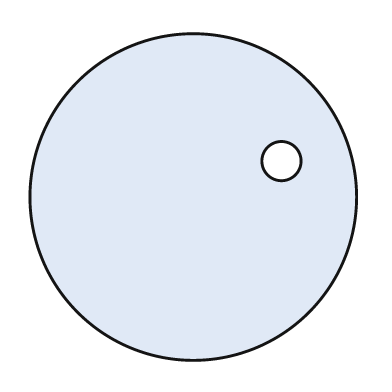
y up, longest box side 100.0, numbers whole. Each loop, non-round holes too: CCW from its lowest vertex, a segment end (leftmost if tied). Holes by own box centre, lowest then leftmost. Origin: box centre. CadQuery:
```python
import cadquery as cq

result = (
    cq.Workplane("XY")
    .moveTo(0.0, 0.0)
    .circle(50.0)
    .moveTo(27.0, 11.0)
    .circle(6.0)
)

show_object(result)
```